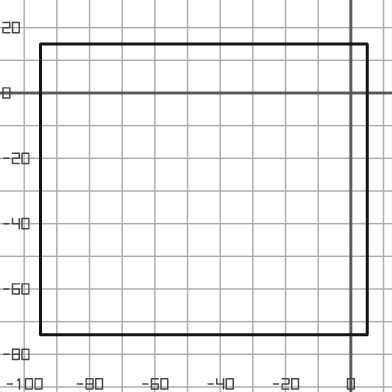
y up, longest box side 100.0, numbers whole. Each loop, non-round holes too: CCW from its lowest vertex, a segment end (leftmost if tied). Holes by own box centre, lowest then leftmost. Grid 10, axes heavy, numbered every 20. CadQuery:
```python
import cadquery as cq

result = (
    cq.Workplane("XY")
    .moveTo(-95.0, -74.0)
    .lineTo(5.0, -74.0)
    .lineTo(5.0, 15.0)
    .lineTo(-95.0, 15.0)
    .close()
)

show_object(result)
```